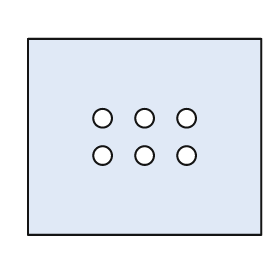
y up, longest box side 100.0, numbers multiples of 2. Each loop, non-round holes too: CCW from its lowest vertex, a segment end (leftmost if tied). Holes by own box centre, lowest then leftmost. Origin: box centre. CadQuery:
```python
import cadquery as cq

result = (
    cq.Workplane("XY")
    .moveTo(-50.0, -42.0)
    .lineTo(50.0, -42.0)
    .lineTo(50.0, 42.0)
    .lineTo(-50.0, 42.0)
    .close()
    .moveTo(-18.0, -8.0)
    .circle(4.0)
    .moveTo(0.0, -8.0)
    .circle(4.0)
    .moveTo(18.0, -8.0)
    .circle(4.0)
    .moveTo(-18.0, 8.0)
    .circle(4.0)
    .moveTo(0.0, 8.0)
    .circle(4.0)
    .moveTo(18.0, 8.0)
    .circle(4.0)
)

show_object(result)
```